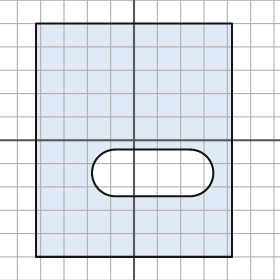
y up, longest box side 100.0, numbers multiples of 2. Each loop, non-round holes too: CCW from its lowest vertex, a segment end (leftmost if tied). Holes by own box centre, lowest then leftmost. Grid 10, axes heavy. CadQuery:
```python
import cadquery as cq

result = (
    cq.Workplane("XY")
    .moveTo(-42.0, -50.0)
    .lineTo(42.0, -50.0)
    .lineTo(42.0, 50.0)
    .lineTo(-42.0, 50.0)
    .close()
    .moveTo(-8.0, -24.0)
    .lineTo(24.0, -24.0)
    .threePointArc((34.0, -14.0), (24.0, -4.0))
    .lineTo(-8.0, -4.0)
    .threePointArc((-18.0, -14.0), (-8.0, -24.0))
    .close()
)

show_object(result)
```